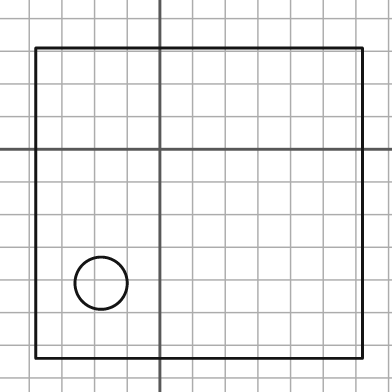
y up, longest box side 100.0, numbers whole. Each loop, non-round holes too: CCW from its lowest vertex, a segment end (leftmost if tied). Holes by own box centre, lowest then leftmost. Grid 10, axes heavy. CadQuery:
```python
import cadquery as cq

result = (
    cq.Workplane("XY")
    .moveTo(-38.0, -64.0)
    .lineTo(62.0, -64.0)
    .lineTo(62.0, 31.0)
    .lineTo(-38.0, 31.0)
    .close()
    .moveTo(-18.0, -41.0)
    .circle(8.0)
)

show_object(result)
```